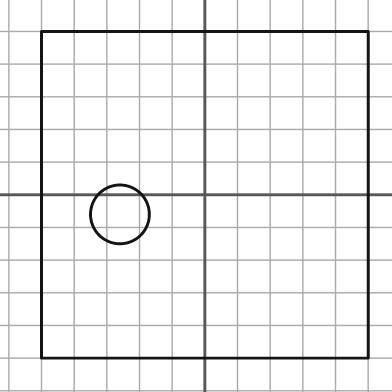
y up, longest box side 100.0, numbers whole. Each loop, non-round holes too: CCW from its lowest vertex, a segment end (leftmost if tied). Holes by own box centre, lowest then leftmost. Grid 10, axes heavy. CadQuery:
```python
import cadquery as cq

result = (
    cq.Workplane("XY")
    .moveTo(-50.0, -50.0)
    .lineTo(50.0, -50.0)
    .lineTo(50.0, 50.0)
    .lineTo(-50.0, 50.0)
    .close()
    .moveTo(-26.0, -6.0)
    .circle(9.0)
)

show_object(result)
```